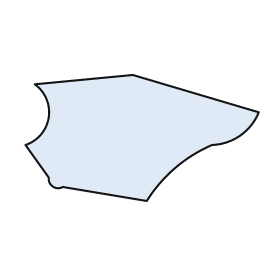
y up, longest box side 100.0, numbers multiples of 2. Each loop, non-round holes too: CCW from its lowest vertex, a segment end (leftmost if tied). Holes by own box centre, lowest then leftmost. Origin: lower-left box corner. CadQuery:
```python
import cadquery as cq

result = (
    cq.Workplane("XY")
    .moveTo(52.0, 0.0)
    .threePointArc((64.0, 14.0), (80.0, 24.0))
    .threePointArc((92.0, 28.0), (100.0, 38.0))
    .lineTo(46.0, 54.0)
    .lineTo(4.0, 50.0)
    .threePointArc((10.0, 36.0), (0.0, 24.0))
    .lineTo(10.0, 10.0)
    .threePointArc((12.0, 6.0), (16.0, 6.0))
    .close()
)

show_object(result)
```